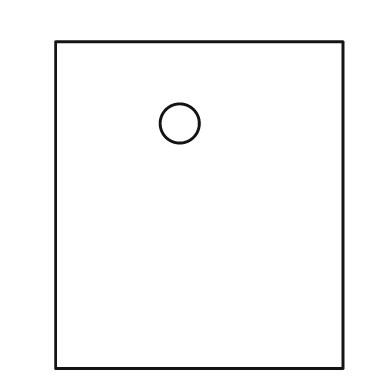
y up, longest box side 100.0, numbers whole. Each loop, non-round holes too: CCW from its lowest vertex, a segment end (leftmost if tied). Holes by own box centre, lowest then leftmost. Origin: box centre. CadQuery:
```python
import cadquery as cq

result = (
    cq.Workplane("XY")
    .moveTo(-44.0, -50.0)
    .lineTo(44.0, -50.0)
    .lineTo(44.0, 50.0)
    .lineTo(-44.0, 50.0)
    .close()
    .moveTo(-6.0, 25.0)
    .circle(6.0)
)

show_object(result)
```